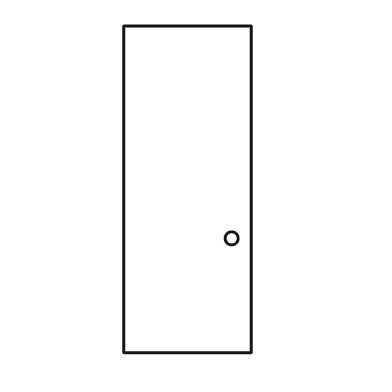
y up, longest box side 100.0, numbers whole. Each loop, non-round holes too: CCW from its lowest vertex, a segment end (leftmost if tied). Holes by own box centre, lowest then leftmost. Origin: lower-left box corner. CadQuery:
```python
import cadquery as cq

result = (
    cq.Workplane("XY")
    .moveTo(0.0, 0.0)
    .lineTo(39.0, 0.0)
    .lineTo(39.0, 100.0)
    .lineTo(0.0, 100.0)
    .close()
    .moveTo(33.0, 35.0)
    .circle(2.0)
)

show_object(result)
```